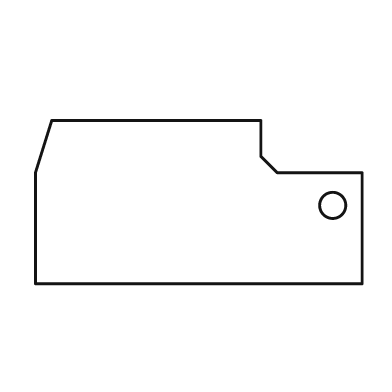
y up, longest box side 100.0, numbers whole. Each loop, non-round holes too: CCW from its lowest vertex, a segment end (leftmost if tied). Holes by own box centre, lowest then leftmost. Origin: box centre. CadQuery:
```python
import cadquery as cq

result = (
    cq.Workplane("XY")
    .moveTo(-50.0, -25.0)
    .lineTo(50.0, -25.0)
    .lineTo(50.0, 9.0)
    .lineTo(24.0, 9.0)
    .lineTo(19.0, 14.0)
    .lineTo(19.0, 25.0)
    .lineTo(-45.0, 25.0)
    .lineTo(-50.0, 9.0)
    .close()
    .moveTo(41.0, -1.0)
    .circle(4.0)
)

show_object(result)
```